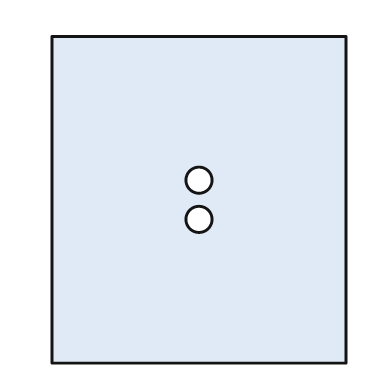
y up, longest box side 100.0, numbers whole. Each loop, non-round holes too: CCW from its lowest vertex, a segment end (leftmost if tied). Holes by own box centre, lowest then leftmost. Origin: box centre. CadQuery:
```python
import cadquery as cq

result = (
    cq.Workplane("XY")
    .moveTo(-45.0, -50.0)
    .lineTo(45.0, -50.0)
    .lineTo(45.0, 50.0)
    .lineTo(-45.0, 50.0)
    .close()
    .moveTo(0.0, -6.0)
    .circle(4.0)
    .moveTo(0.0, 6.0)
    .circle(4.0)
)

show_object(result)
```